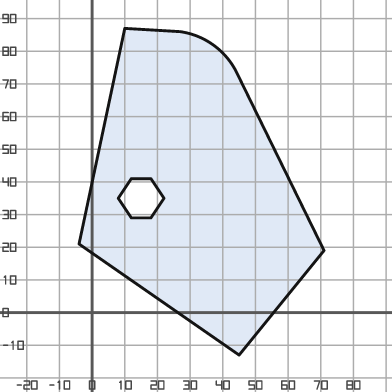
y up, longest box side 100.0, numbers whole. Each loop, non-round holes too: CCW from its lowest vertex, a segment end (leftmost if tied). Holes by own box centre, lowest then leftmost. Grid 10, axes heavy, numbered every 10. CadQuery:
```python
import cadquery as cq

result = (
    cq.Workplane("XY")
    .moveTo(45.0, -13.0)
    .lineTo(71.0, 19.0)
    .lineTo(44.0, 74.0)
    .threePointArc((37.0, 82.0), (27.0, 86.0))
    .lineTo(10.0, 87.0)
    .lineTo(-4.0, 21.0)
    .close()
    .moveTo(12.0, 29.0)
    .lineTo(18.0, 29.0)
    .lineTo(22.0, 35.0)
    .lineTo(18.0, 41.0)
    .lineTo(12.0, 41.0)
    .lineTo(8.0, 35.0)
    .close()
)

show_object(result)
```